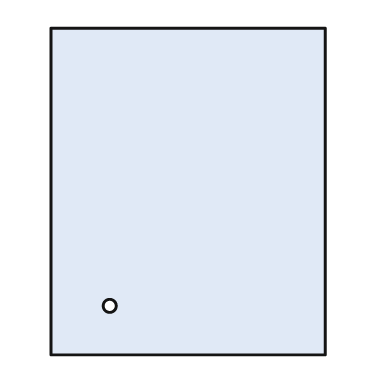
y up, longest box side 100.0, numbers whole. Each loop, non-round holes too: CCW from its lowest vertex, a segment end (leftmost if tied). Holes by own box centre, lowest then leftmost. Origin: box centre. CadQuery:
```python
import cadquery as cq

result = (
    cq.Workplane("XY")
    .moveTo(-42.0, -50.0)
    .lineTo(42.0, -50.0)
    .lineTo(42.0, 50.0)
    .lineTo(-42.0, 50.0)
    .close()
    .moveTo(-24.0, -35.0)
    .circle(2.0)
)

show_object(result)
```